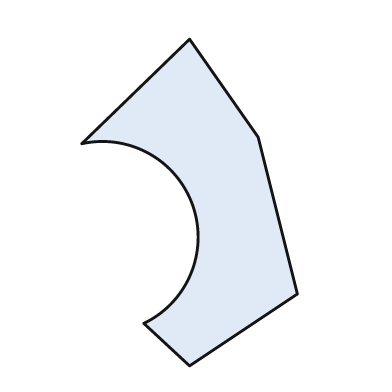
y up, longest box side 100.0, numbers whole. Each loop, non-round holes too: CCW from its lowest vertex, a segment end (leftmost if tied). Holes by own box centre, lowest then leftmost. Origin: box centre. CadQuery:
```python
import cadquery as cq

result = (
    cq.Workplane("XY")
    .moveTo(0.0, -50.0)
    .lineTo(33.0, -28.0)
    .lineTo(21.0, 20.0)
    .lineTo(0.0, 50.0)
    .lineTo(-33.0, 18.0)
    .threePointArc((1.0, -1.0), (-14.0, -37.0))
    .close()
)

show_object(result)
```